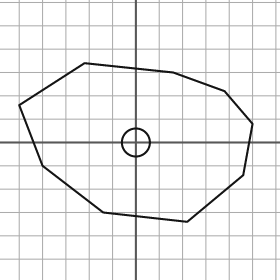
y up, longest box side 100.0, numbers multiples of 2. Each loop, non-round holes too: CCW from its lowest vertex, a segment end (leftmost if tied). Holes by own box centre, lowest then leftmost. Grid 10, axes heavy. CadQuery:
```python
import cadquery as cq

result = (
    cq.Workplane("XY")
    .moveTo(22.0, -34.0)
    .lineTo(46.0, -14.0)
    .lineTo(50.0, 8.0)
    .lineTo(38.0, 22.0)
    .lineTo(16.0, 30.0)
    .lineTo(-22.0, 34.0)
    .lineTo(-50.0, 16.0)
    .lineTo(-40.0, -10.0)
    .lineTo(-14.0, -30.0)
    .close()
    .moveTo(0.0, 0.0)
    .circle(6.0)
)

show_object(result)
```